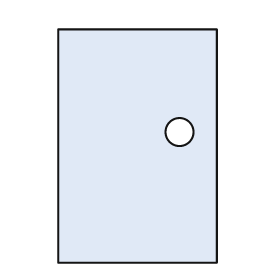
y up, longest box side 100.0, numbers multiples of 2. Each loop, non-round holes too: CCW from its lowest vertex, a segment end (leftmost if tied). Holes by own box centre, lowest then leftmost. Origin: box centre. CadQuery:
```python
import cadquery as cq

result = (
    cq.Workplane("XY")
    .moveTo(-34.0, -50.0)
    .lineTo(34.0, -50.0)
    .lineTo(34.0, 50.0)
    .lineTo(-34.0, 50.0)
    .close()
    .moveTo(18.0, 6.0)
    .circle(6.0)
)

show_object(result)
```